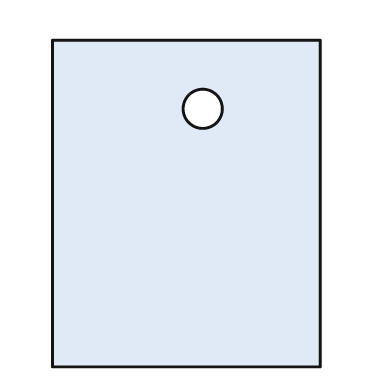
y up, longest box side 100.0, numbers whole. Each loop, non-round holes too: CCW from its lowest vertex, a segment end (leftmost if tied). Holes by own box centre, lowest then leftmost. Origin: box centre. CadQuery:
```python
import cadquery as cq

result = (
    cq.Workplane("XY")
    .moveTo(-41.0, -50.0)
    .lineTo(41.0, -50.0)
    .lineTo(41.0, 50.0)
    .lineTo(-41.0, 50.0)
    .close()
    .moveTo(5.0, 29.0)
    .circle(6.0)
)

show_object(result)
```